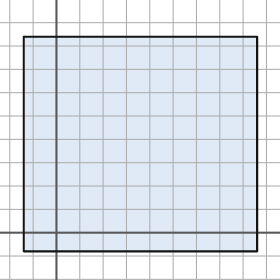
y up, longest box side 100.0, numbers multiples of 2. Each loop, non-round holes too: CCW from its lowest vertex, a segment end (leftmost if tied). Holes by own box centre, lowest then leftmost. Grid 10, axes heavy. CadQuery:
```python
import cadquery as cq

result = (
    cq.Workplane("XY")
    .moveTo(-14.0, -8.0)
    .lineTo(86.0, -8.0)
    .lineTo(86.0, 84.0)
    .lineTo(-14.0, 84.0)
    .close()
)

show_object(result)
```